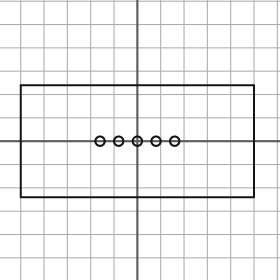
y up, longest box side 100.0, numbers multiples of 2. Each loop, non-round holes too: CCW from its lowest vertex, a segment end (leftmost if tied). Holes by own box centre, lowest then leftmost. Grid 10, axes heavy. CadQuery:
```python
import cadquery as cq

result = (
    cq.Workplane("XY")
    .moveTo(-50.0, -24.0)
    .lineTo(50.0, -24.0)
    .lineTo(50.0, 24.0)
    .lineTo(-50.0, 24.0)
    .close()
    .moveTo(-16.0, 0.0)
    .circle(2.0)
    .moveTo(-8.0, 0.0)
    .circle(2.0)
    .moveTo(0.0, 0.0)
    .circle(2.0)
    .moveTo(8.0, 0.0)
    .circle(2.0)
    .moveTo(16.0, 0.0)
    .circle(2.0)
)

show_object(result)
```